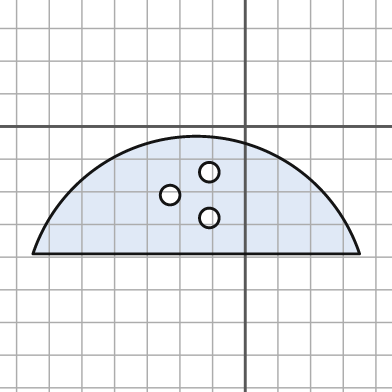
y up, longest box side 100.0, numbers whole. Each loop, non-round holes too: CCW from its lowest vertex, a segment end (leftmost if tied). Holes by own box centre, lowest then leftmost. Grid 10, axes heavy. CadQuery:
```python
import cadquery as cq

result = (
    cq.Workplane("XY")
    .moveTo(-65.0, -39.0)
    .lineTo(35.0, -39.0)
    .threePointArc((-15.0, -3.0), (-65.0, -39.0))
    .close()
    .moveTo(-11.0, -28.0)
    .circle(3.0)
    .moveTo(-23.0, -21.0)
    .circle(3.0)
    .moveTo(-11.0, -14.0)
    .circle(3.0)
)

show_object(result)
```